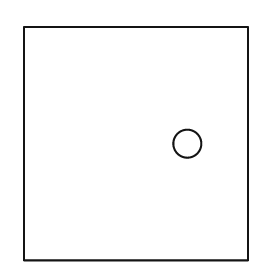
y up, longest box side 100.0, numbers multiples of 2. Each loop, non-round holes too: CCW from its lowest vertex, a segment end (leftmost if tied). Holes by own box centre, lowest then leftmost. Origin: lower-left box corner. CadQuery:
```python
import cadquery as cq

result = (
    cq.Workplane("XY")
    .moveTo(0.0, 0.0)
    .lineTo(96.0, 0.0)
    .lineTo(96.0, 100.0)
    .lineTo(0.0, 100.0)
    .close()
    .moveTo(70.0, 50.0)
    .circle(6.0)
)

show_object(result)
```